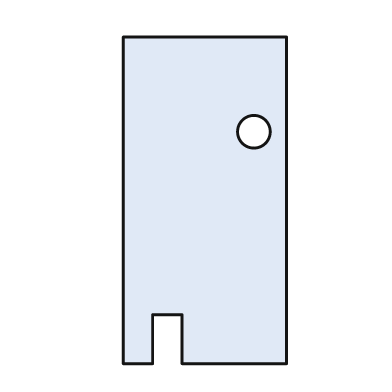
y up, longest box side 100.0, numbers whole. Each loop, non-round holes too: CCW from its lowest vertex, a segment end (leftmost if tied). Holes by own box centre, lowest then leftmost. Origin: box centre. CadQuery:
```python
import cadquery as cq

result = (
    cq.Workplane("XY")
    .moveTo(-25.0, -50.0)
    .lineTo(-16.0, -50.0)
    .lineTo(-16.0, -35.0)
    .lineTo(-7.0, -35.0)
    .lineTo(-7.0, -50.0)
    .lineTo(25.0, -50.0)
    .lineTo(25.0, 50.0)
    .lineTo(-25.0, 50.0)
    .close()
    .moveTo(15.0, 21.0)
    .circle(5.0)
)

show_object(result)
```